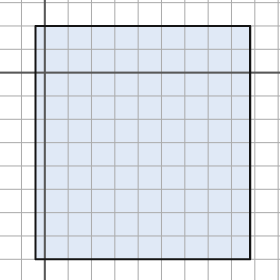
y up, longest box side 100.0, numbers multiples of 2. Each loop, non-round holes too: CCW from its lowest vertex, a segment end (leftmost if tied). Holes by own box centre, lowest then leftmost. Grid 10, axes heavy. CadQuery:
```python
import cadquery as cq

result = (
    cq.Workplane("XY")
    .moveTo(-4.0, -80.0)
    .lineTo(88.0, -80.0)
    .lineTo(88.0, 20.0)
    .lineTo(-4.0, 20.0)
    .close()
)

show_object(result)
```